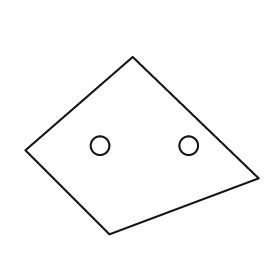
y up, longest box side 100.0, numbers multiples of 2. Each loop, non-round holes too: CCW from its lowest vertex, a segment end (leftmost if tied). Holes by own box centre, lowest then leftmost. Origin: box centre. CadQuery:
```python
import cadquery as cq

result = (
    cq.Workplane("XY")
    .moveTo(-14.0, -38.0)
    .lineTo(50.0, -14.0)
    .lineTo(-4.0, 38.0)
    .lineTo(-50.0, -2.0)
    .close()
    .moveTo(-18.0, 0.0)
    .circle(4.0)
    .moveTo(20.0, 0.0)
    .circle(4.0)
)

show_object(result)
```